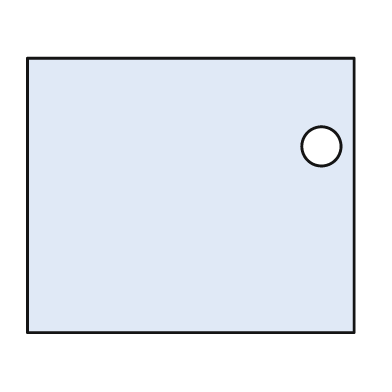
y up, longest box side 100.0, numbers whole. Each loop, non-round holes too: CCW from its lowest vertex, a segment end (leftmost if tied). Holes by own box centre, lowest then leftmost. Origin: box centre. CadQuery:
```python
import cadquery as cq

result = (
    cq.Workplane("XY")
    .moveTo(-50.0, -42.0)
    .lineTo(50.0, -42.0)
    .lineTo(50.0, 42.0)
    .lineTo(-50.0, 42.0)
    .close()
    .moveTo(40.0, 15.0)
    .circle(6.0)
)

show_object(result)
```